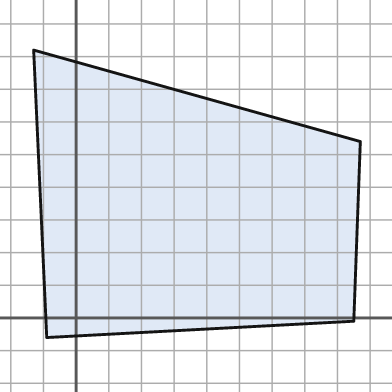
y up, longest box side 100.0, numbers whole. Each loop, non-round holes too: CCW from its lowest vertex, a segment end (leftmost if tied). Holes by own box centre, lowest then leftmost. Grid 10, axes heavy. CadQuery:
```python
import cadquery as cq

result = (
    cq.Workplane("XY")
    .moveTo(-9.0, -6.0)
    .lineTo(85.0, -1.0)
    .lineTo(87.0, 54.0)
    .lineTo(-13.0, 82.0)
    .close()
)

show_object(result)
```